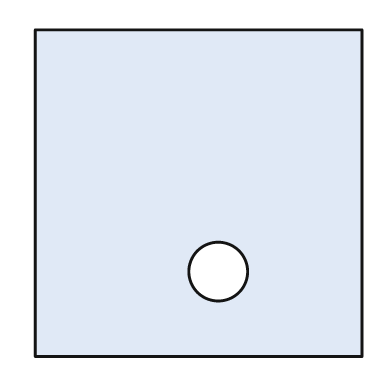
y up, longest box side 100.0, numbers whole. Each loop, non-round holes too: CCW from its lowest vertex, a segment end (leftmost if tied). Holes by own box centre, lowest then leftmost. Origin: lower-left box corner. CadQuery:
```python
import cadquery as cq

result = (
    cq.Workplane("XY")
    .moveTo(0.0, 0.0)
    .lineTo(100.0, 0.0)
    .lineTo(100.0, 100.0)
    .lineTo(0.0, 100.0)
    .close()
    .moveTo(56.0, 26.0)
    .circle(9.0)
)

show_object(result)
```